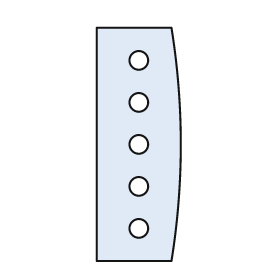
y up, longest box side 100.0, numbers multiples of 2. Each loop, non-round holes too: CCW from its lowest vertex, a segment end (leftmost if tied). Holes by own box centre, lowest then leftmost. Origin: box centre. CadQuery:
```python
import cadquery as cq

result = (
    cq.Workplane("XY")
    .moveTo(-18.0, -50.0)
    .lineTo(14.0, -50.0)
    .threePointArc((18.0, 0.0), (14.0, 50.0))
    .lineTo(-18.0, 50.0)
    .close()
    .moveTo(0.0, -36.0)
    .circle(4.0)
    .moveTo(0.0, -18.0)
    .circle(4.0)
    .moveTo(0.0, 0.0)
    .circle(4.0)
    .moveTo(0.0, 18.0)
    .circle(4.0)
    .moveTo(0.0, 36.0)
    .circle(4.0)
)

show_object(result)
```